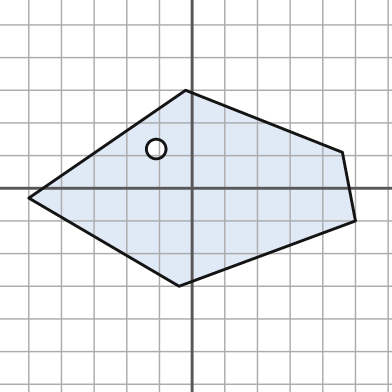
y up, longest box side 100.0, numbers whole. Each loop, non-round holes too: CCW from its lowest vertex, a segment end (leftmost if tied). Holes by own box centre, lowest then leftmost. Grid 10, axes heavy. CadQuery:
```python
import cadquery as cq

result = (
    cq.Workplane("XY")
    .moveTo(-4.0, -30.0)
    .lineTo(50.0, -10.0)
    .lineTo(46.0, 11.0)
    .lineTo(-2.0, 30.0)
    .lineTo(-50.0, -3.0)
    .close()
    .moveTo(-11.0, 12.0)
    .circle(3.0)
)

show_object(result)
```